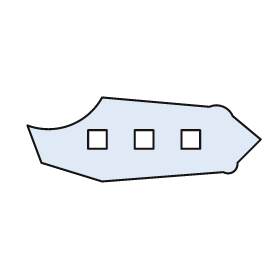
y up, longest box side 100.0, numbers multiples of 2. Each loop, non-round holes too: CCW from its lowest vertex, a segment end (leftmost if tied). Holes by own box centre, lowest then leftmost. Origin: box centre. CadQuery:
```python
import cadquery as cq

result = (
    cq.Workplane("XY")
    .moveTo(-18.0, -18.0)
    .lineTo(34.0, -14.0)
    .threePointArc((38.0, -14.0), (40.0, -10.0))
    .lineTo(50.0, 0.0)
    .lineTo(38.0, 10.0)
    .threePointArc((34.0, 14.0), (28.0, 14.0))
    .lineTo(-18.0, 18.0)
    .threePointArc((-32.0, 6.0), (-50.0, 6.0))
    .lineTo(-44.0, -10.0)
    .close()
    .moveTo(-24.0, -4.0)
    .lineTo(-16.0, -4.0)
    .lineTo(-16.0, 4.0)
    .lineTo(-24.0, 4.0)
    .close()
    .moveTo(-4.0, -4.0)
    .lineTo(4.0, -4.0)
    .lineTo(4.0, 4.0)
    .lineTo(-4.0, 4.0)
    .close()
    .moveTo(16.0, -4.0)
    .lineTo(24.0, -4.0)
    .lineTo(24.0, 4.0)
    .lineTo(16.0, 4.0)
    .close()
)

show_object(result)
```